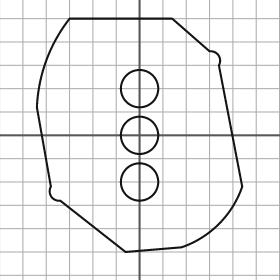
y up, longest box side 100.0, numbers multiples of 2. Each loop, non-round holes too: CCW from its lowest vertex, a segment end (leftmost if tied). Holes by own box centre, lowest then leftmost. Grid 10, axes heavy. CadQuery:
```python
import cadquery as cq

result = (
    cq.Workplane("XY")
    .moveTo(-6.0, -50.0)
    .lineTo(18.0, -48.0)
    .threePointArc((34.0, -38.0), (44.0, -22.0))
    .lineTo(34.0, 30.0)
    .threePointArc((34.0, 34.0), (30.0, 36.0))
    .lineTo(14.0, 50.0)
    .lineTo(-30.0, 50.0)
    .threePointArc((-40.0, 32.0), (-44.0, 12.0))
    .lineTo(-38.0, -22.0)
    .threePointArc((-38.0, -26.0), (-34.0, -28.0))
    .close()
    .moveTo(0.0, -20.0)
    .circle(8.0)
    .moveTo(0.0, 0.0)
    .circle(8.0)
    .moveTo(0.0, 20.0)
    .circle(8.0)
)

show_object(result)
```